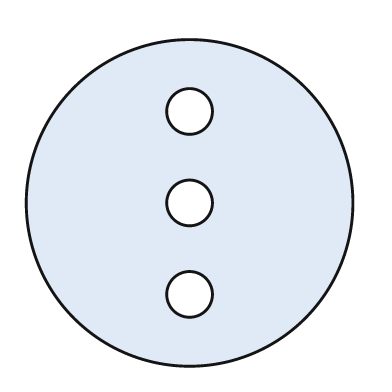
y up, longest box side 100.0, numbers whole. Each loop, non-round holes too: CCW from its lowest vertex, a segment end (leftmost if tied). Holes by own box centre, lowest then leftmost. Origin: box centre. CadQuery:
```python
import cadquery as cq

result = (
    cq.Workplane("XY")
    .moveTo(0.0, 0.0)
    .circle(50.0)
    .moveTo(0.0, -28.0)
    .circle(7.0)
    .moveTo(0.0, 0.0)
    .circle(7.0)
    .moveTo(0.0, 28.0)
    .circle(7.0)
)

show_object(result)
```